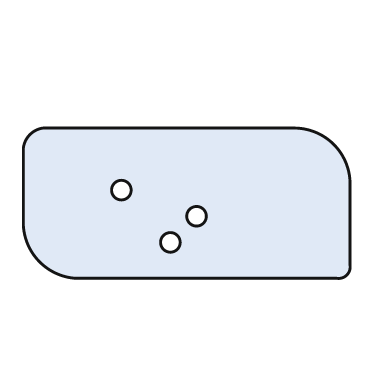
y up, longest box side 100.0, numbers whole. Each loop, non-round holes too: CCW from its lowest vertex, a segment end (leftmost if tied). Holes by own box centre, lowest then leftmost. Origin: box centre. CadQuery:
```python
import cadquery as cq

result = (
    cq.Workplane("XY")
    .moveTo(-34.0, -23.0)
    .lineTo(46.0, -23.0)
    .threePointArc((49.0, -22.0), (50.0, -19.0))
    .lineTo(50.0, 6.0)
    .threePointArc((45.0, 18.0), (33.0, 23.0))
    .lineTo(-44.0, 23.0)
    .threePointArc((-48.0, 21.0), (-50.0, 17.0))
    .lineTo(-50.0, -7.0)
    .threePointArc((-45.0, -18.0), (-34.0, -23.0))
    .close()
    .moveTo(-5.0, -12.0)
    .circle(3.0)
    .moveTo(3.0, -4.0)
    .circle(3.0)
    .moveTo(-20.0, 4.0)
    .circle(3.0)
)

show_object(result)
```